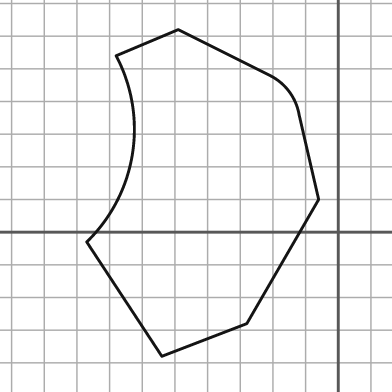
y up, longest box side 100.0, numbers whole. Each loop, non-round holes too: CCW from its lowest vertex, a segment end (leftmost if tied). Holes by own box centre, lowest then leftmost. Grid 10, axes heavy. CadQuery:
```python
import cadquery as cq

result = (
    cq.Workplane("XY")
    .moveTo(-54.0, -38.0)
    .lineTo(-28.0, -28.0)
    .lineTo(-6.0, 10.0)
    .lineTo(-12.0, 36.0)
    .threePointArc((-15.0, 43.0), (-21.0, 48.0))
    .lineTo(-49.0, 62.0)
    .lineTo(-68.0, 54.0)
    .threePointArc((-63.0, 24.0), (-77.0, -3.0))
    .close()
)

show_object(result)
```